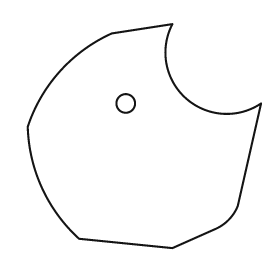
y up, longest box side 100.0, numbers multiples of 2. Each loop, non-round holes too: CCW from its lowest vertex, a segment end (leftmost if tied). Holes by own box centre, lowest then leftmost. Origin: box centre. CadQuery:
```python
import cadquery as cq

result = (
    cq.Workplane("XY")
    .moveTo(12.0, -48.0)
    .lineTo(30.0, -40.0)
    .threePointArc((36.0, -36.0), (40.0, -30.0))
    .lineTo(50.0, 14.0)
    .threePointArc((18.0, 16.0), (12.0, 48.0))
    .lineTo(-14.0, 44.0)
    .threePointArc((-36.0, 28.0), (-50.0, 4.0))
    .threePointArc((-44.0, -22.0), (-28.0, -44.0))
    .close()
    .moveTo(-8.0, 14.0)
    .circle(4.0)
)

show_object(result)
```